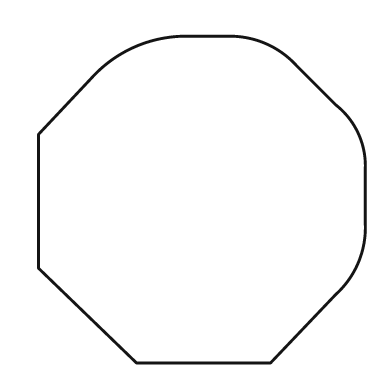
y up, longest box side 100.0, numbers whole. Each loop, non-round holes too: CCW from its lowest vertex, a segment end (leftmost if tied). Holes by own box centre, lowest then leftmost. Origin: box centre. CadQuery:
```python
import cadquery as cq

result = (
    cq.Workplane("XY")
    .moveTo(-20.0, -50.0)
    .lineTo(21.0, -50.0)
    .lineTo(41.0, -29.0)
    .threePointArc((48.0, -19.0), (50.0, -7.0))
    .lineTo(50.0, 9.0)
    .threePointArc((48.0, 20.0), (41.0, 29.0))
    .lineTo(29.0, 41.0)
    .threePointArc((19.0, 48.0), (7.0, 50.0))
    .lineTo(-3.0, 50.0)
    .threePointArc((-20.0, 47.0), (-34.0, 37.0))
    .lineTo(-50.0, 20.0)
    .lineTo(-50.0, -21.0)
    .close()
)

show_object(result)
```